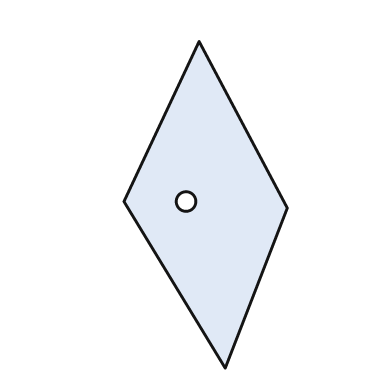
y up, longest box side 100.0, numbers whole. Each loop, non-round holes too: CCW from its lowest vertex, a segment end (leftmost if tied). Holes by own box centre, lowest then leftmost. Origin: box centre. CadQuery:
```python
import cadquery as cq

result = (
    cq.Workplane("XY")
    .moveTo(6.0, -50.0)
    .lineTo(25.0, -1.0)
    .lineTo(-2.0, 50.0)
    .lineTo(-25.0, 1.0)
    .close()
    .moveTo(-6.0, 1.0)
    .circle(3.0)
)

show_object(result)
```